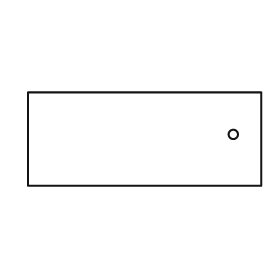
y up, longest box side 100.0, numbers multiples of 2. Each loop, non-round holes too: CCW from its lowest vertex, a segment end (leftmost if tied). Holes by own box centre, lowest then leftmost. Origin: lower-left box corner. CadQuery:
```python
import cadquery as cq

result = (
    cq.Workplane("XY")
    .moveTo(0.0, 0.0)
    .lineTo(100.0, 0.0)
    .lineTo(100.0, 40.0)
    .lineTo(0.0, 40.0)
    .close()
    .moveTo(88.0, 22.0)
    .circle(2.0)
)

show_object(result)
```